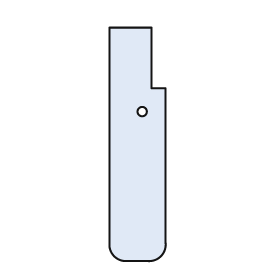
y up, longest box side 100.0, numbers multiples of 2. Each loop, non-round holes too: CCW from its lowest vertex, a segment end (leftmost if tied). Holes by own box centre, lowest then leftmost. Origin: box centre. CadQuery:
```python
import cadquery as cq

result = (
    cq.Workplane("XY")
    .moveTo(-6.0, -50.0)
    .lineTo(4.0, -50.0)
    .threePointArc((10.0, -48.0), (12.0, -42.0))
    .lineTo(12.0, 24.0)
    .lineTo(6.0, 24.0)
    .lineTo(6.0, 50.0)
    .lineTo(-12.0, 50.0)
    .lineTo(-12.0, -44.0)
    .threePointArc((-10.0, -48.0), (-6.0, -50.0))
    .close()
    .moveTo(2.0, 14.0)
    .circle(2.0)
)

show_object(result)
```